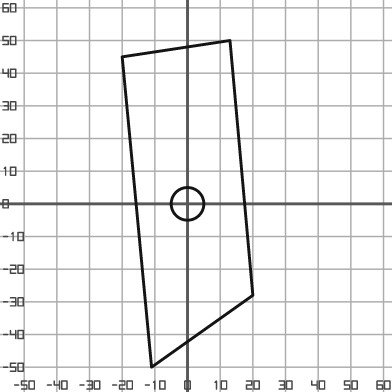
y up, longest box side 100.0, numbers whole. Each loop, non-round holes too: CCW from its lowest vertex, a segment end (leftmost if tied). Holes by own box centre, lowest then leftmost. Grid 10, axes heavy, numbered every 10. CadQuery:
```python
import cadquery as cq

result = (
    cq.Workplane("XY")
    .moveTo(-11.0, -50.0)
    .lineTo(20.0, -28.0)
    .lineTo(13.0, 50.0)
    .lineTo(-20.0, 45.0)
    .close()
    .moveTo(0.0, 0.0)
    .circle(5.0)
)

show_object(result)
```